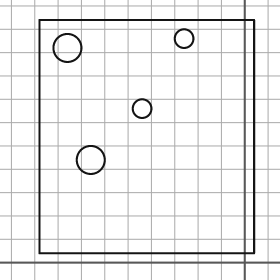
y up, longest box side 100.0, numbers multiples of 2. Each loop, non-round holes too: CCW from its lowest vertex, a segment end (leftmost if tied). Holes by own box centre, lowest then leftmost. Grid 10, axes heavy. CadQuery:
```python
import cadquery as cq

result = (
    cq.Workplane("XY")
    .moveTo(-88.0, 4.0)
    .lineTo(4.0, 4.0)
    .lineTo(4.0, 104.0)
    .lineTo(-88.0, 104.0)
    .close()
    .moveTo(-66.0, 44.0)
    .circle(6.0)
    .moveTo(-44.0, 66.0)
    .circle(4.0)
    .moveTo(-76.0, 92.0)
    .circle(6.0)
    .moveTo(-26.0, 96.0)
    .circle(4.0)
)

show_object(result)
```